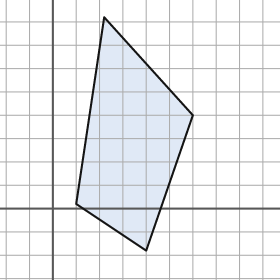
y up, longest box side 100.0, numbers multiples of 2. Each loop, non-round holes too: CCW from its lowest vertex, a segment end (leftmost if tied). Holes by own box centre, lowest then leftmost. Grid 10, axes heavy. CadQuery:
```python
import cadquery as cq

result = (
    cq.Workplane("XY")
    .moveTo(40.0, -18.0)
    .lineTo(60.0, 40.0)
    .lineTo(22.0, 82.0)
    .lineTo(10.0, 2.0)
    .close()
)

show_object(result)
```